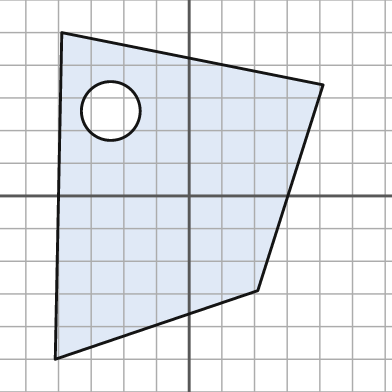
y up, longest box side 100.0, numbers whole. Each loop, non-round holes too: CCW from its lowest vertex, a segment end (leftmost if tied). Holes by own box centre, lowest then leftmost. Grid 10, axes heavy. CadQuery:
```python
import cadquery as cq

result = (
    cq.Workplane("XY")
    .moveTo(-41.0, -50.0)
    .lineTo(21.0, -29.0)
    .lineTo(41.0, 34.0)
    .lineTo(-39.0, 50.0)
    .close()
    .moveTo(-24.0, 26.0)
    .circle(9.0)
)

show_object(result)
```